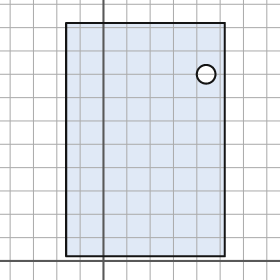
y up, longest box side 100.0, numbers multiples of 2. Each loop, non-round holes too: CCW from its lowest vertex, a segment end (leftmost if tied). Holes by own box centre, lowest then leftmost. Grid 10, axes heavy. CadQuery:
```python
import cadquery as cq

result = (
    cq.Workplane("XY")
    .moveTo(-16.0, 2.0)
    .lineTo(52.0, 2.0)
    .lineTo(52.0, 102.0)
    .lineTo(-16.0, 102.0)
    .close()
    .moveTo(44.0, 80.0)
    .circle(4.0)
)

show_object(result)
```